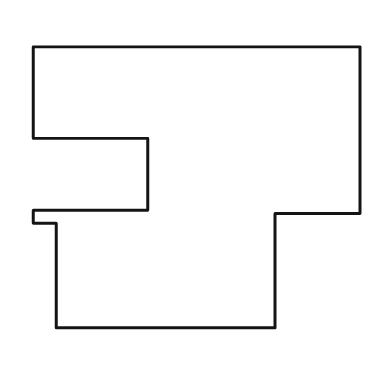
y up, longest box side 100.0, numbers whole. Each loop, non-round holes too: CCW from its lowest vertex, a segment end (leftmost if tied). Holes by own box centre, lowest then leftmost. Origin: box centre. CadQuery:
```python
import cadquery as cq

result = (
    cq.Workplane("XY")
    .moveTo(-43.0, -43.0)
    .lineTo(24.0, -43.0)
    .lineTo(24.0, -8.0)
    .lineTo(50.0, -8.0)
    .lineTo(50.0, 43.0)
    .lineTo(-50.0, 43.0)
    .lineTo(-50.0, 15.0)
    .lineTo(-15.0, 15.0)
    .lineTo(-15.0, -7.0)
    .lineTo(-50.0, -7.0)
    .lineTo(-50.0, -11.0)
    .lineTo(-43.0, -11.0)
    .close()
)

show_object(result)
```